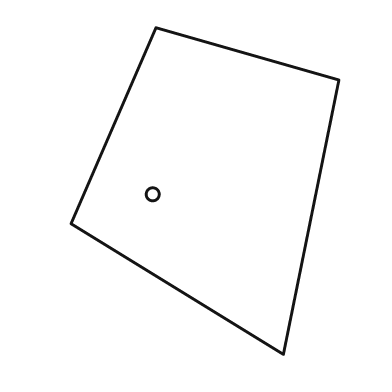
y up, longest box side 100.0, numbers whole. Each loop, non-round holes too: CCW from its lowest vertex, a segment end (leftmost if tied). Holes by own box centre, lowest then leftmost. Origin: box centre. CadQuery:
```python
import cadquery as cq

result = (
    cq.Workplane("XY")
    .moveTo(24.0, -50.0)
    .lineTo(41.0, 34.0)
    .lineTo(-15.0, 50.0)
    .lineTo(-41.0, -10.0)
    .close()
    .moveTo(-16.0, -1.0)
    .circle(2.0)
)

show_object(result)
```